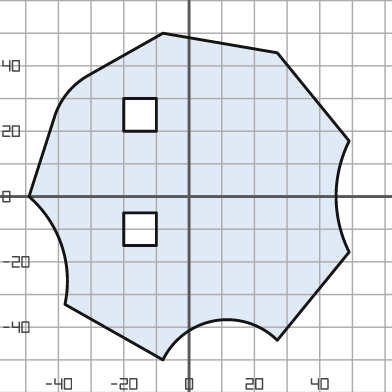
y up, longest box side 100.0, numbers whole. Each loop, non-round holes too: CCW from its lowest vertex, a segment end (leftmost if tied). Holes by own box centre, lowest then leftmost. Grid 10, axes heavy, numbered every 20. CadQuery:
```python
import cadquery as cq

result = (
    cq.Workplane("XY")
    .moveTo(-8.0, -50.0)
    .threePointArc((8.0, -38.0), (27.0, -44.0))
    .lineTo(49.0, -17.0)
    .threePointArc((45.0, 0.0), (49.0, 17.0))
    .lineTo(27.0, 44.0)
    .lineTo(-8.0, 50.0)
    .lineTo(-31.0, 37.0)
    .threePointArc((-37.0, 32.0), (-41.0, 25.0))
    .lineTo(-49.0, 0.0)
    .threePointArc((-39.0, -15.0), (-38.0, -33.0))
    .close()
    .moveTo(-20.0, -15.0)
    .lineTo(-10.0, -15.0)
    .lineTo(-10.0, -5.0)
    .lineTo(-20.0, -5.0)
    .close()
    .moveTo(-20.0, 20.0)
    .lineTo(-10.0, 20.0)
    .lineTo(-10.0, 30.0)
    .lineTo(-20.0, 30.0)
    .close()
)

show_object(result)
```